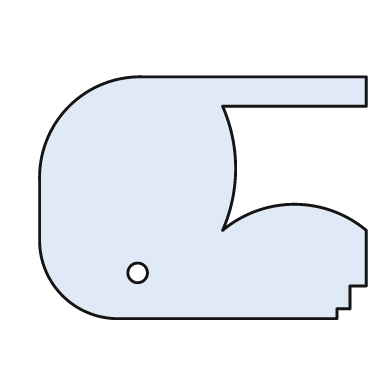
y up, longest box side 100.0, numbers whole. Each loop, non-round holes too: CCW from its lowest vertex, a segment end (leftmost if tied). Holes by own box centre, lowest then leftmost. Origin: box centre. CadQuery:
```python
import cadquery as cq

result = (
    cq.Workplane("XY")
    .moveTo(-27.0, -37.0)
    .lineTo(41.0, -37.0)
    .lineTo(41.0, -34.0)
    .lineTo(45.0, -34.0)
    .lineTo(45.0, -27.0)
    .lineTo(50.0, -27.0)
    .lineTo(50.0, -10.0)
    .threePointArc((28.0, -2.0), (6.0, -10.0))
    .threePointArc((10.0, 9.0), (6.0, 28.0))
    .lineTo(50.0, 28.0)
    .lineTo(50.0, 37.0)
    .lineTo(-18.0, 37.0)
    .threePointArc((-41.0, 28.0), (-50.0, 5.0))
    .lineTo(-50.0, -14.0)
    .threePointArc((-43.0, -30.0), (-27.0, -37.0))
    .close()
    .moveTo(-20.0, -23.0)
    .circle(3.0)
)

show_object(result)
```